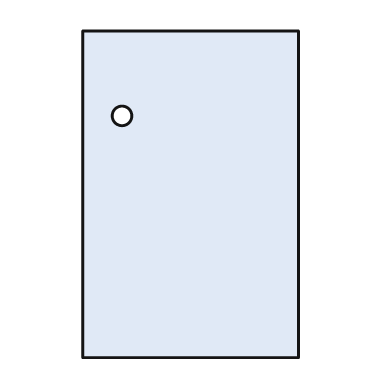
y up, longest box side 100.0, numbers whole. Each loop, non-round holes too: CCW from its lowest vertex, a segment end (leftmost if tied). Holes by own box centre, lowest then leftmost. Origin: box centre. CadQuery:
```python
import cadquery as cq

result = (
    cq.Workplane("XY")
    .moveTo(-33.0, -50.0)
    .lineTo(33.0, -50.0)
    .lineTo(33.0, 50.0)
    .lineTo(-33.0, 50.0)
    .close()
    .moveTo(-21.0, 24.0)
    .circle(3.0)
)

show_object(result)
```